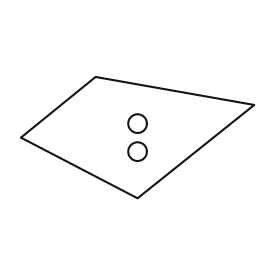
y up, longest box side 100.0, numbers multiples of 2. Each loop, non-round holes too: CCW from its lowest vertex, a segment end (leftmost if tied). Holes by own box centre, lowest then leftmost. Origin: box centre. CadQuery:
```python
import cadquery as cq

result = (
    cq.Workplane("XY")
    .moveTo(0.0, -26.0)
    .lineTo(50.0, 14.0)
    .lineTo(-18.0, 26.0)
    .lineTo(-50.0, 0.0)
    .close()
    .moveTo(0.0, -6.0)
    .circle(4.0)
    .moveTo(0.0, 6.0)
    .circle(4.0)
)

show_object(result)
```